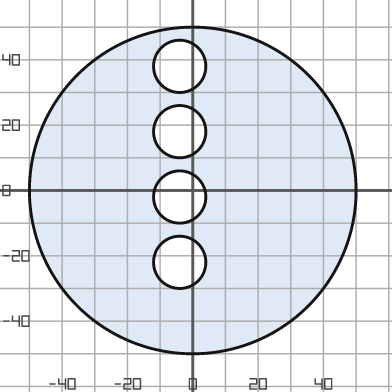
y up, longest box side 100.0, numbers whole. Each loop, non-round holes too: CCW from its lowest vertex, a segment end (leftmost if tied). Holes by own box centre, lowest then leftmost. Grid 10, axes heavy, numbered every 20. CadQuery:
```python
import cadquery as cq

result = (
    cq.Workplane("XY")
    .moveTo(0.0, 0.0)
    .circle(50.0)
    .moveTo(-4.0, -22.0)
    .circle(8.0)
    .moveTo(-4.0, -2.0)
    .circle(8.0)
    .moveTo(-4.0, 18.0)
    .circle(8.0)
    .moveTo(-4.0, 38.0)
    .circle(8.0)
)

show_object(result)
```